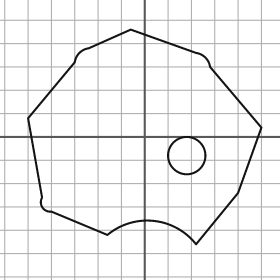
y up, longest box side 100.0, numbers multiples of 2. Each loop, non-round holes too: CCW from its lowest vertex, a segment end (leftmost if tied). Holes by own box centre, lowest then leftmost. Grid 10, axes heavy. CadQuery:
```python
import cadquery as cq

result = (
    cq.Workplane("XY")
    .moveTo(22.0, -46.0)
    .lineTo(40.0, -24.0)
    .lineTo(50.0, 4.0)
    .lineTo(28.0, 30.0)
    .threePointArc((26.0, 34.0), (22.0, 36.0))
    .lineTo(-6.0, 46.0)
    .lineTo(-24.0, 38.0)
    .threePointArc((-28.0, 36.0), (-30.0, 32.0))
    .lineTo(-50.0, 8.0)
    .lineTo(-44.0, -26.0)
    .threePointArc((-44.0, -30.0), (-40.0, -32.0))
    .lineTo(-16.0, -42.0)
    .threePointArc((4.0, -36.0), (22.0, -46.0))
    .close()
    .moveTo(18.0, -8.0)
    .circle(8.0)
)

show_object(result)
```